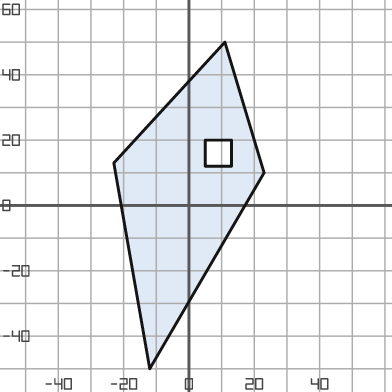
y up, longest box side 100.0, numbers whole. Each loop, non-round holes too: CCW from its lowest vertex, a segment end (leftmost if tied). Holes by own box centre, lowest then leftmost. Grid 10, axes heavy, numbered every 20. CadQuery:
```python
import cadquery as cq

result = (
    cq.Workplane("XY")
    .moveTo(-12.0, -50.0)
    .lineTo(23.0, 10.0)
    .lineTo(11.0, 50.0)
    .lineTo(-23.0, 13.0)
    .close()
    .moveTo(5.0, 12.0)
    .lineTo(13.0, 12.0)
    .lineTo(13.0, 20.0)
    .lineTo(5.0, 20.0)
    .close()
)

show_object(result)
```